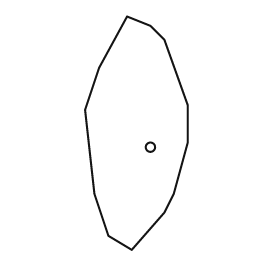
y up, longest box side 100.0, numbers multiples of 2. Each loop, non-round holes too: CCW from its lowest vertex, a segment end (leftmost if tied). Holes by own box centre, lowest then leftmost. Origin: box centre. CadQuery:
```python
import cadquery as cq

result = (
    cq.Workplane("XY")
    .moveTo(-2.0, -50.0)
    .lineTo(12.0, -34.0)
    .lineTo(16.0, -26.0)
    .lineTo(22.0, -4.0)
    .lineTo(22.0, 12.0)
    .lineTo(12.0, 40.0)
    .lineTo(6.0, 46.0)
    .lineTo(-4.0, 50.0)
    .lineTo(-16.0, 28.0)
    .lineTo(-22.0, 10.0)
    .lineTo(-18.0, -26.0)
    .lineTo(-12.0, -44.0)
    .close()
    .moveTo(6.0, -6.0)
    .circle(2.0)
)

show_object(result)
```